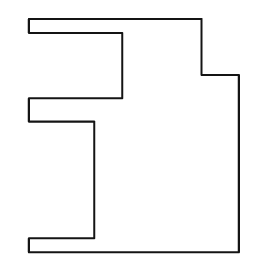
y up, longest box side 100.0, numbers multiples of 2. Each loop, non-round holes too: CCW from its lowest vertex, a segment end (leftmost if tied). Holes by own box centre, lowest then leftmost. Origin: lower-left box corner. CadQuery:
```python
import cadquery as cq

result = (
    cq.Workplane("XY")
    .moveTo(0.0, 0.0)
    .lineTo(90.0, 0.0)
    .lineTo(90.0, 76.0)
    .lineTo(74.0, 76.0)
    .lineTo(74.0, 100.0)
    .lineTo(0.0, 100.0)
    .lineTo(0.0, 94.0)
    .lineTo(40.0, 94.0)
    .lineTo(40.0, 66.0)
    .lineTo(0.0, 66.0)
    .lineTo(0.0, 56.0)
    .lineTo(28.0, 56.0)
    .lineTo(28.0, 6.0)
    .lineTo(0.0, 6.0)
    .close()
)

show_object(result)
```